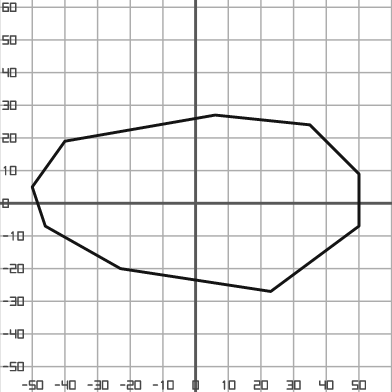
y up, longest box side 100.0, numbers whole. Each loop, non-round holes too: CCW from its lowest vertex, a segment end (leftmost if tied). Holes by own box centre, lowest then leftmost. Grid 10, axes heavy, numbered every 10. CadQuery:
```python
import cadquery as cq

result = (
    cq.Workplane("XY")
    .moveTo(23.0, -27.0)
    .lineTo(50.0, -7.0)
    .lineTo(50.0, 9.0)
    .lineTo(35.0, 24.0)
    .lineTo(6.0, 27.0)
    .lineTo(-40.0, 19.0)
    .lineTo(-50.0, 5.0)
    .lineTo(-46.0, -7.0)
    .lineTo(-23.0, -20.0)
    .close()
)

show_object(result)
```